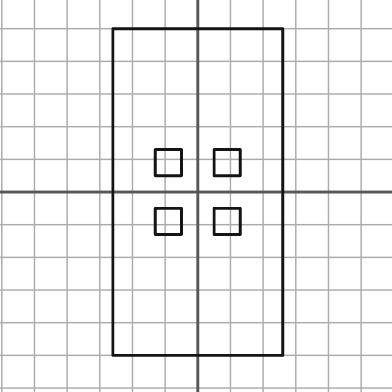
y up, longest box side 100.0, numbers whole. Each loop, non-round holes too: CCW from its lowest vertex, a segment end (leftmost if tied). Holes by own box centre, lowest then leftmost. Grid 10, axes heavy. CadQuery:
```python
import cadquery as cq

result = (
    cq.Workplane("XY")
    .moveTo(-26.0, -50.0)
    .lineTo(26.0, -50.0)
    .lineTo(26.0, 50.0)
    .lineTo(-26.0, 50.0)
    .close()
    .moveTo(-13.0, -13.0)
    .lineTo(-5.0, -13.0)
    .lineTo(-5.0, -5.0)
    .lineTo(-13.0, -5.0)
    .close()
    .moveTo(5.0, -13.0)
    .lineTo(13.0, -13.0)
    .lineTo(13.0, -5.0)
    .lineTo(5.0, -5.0)
    .close()
    .moveTo(-13.0, 5.0)
    .lineTo(-5.0, 5.0)
    .lineTo(-5.0, 13.0)
    .lineTo(-13.0, 13.0)
    .close()
    .moveTo(5.0, 5.0)
    .lineTo(13.0, 5.0)
    .lineTo(13.0, 13.0)
    .lineTo(5.0, 13.0)
    .close()
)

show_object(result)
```